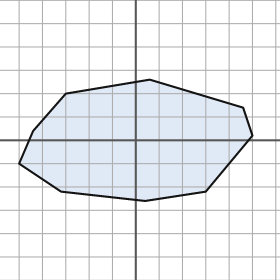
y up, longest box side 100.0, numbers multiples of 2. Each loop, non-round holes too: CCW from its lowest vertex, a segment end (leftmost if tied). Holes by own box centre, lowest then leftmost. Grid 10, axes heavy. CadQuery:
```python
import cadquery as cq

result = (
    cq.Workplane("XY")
    .moveTo(4.0, -26.0)
    .lineTo(30.0, -22.0)
    .lineTo(50.0, 2.0)
    .lineTo(46.0, 14.0)
    .lineTo(6.0, 26.0)
    .lineTo(-30.0, 20.0)
    .lineTo(-44.0, 4.0)
    .lineTo(-50.0, -10.0)
    .lineTo(-32.0, -22.0)
    .close()
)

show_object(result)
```